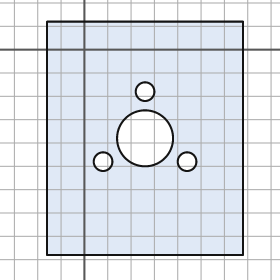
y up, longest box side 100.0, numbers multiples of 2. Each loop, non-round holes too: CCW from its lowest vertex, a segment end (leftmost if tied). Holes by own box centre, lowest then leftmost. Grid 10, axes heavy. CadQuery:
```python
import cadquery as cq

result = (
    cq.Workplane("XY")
    .moveTo(-16.0, -88.0)
    .lineTo(68.0, -88.0)
    .lineTo(68.0, 12.0)
    .lineTo(-16.0, 12.0)
    .close()
    .moveTo(8.0, -48.0)
    .circle(4.0)
    .moveTo(44.0, -48.0)
    .circle(4.0)
    .moveTo(26.0, -38.0)
    .circle(12.0)
    .moveTo(26.0, -18.0)
    .circle(4.0)
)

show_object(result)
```